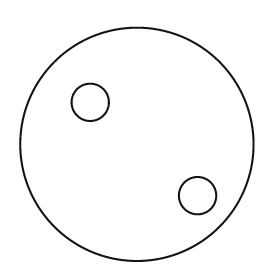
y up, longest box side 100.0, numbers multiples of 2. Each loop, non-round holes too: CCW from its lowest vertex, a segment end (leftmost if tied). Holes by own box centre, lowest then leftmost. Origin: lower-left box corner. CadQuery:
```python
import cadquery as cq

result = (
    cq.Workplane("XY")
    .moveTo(50.0, 50.0)
    .circle(50.0)
    .moveTo(76.0, 28.0)
    .circle(8.0)
    .moveTo(30.0, 68.0)
    .circle(8.0)
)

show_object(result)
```